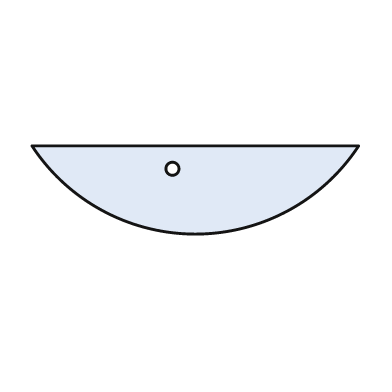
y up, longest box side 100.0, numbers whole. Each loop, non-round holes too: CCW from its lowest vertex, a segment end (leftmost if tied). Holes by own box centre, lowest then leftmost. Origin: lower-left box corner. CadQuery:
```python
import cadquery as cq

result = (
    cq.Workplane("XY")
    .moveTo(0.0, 27.0)
    .threePointArc((50.0, 0.0), (100.0, 27.0))
    .close()
    .moveTo(43.0, 20.0)
    .circle(2.0)
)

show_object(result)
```